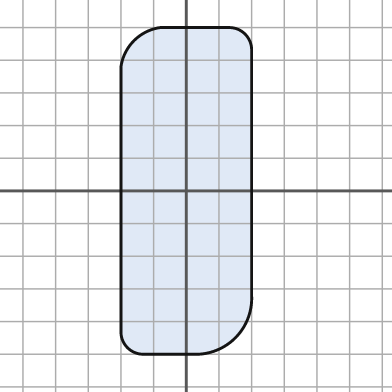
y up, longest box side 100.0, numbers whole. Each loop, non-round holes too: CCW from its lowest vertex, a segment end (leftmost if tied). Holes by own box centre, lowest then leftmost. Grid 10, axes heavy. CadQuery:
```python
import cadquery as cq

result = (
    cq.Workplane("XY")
    .moveTo(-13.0, -50.0)
    .lineTo(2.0, -50.0)
    .threePointArc((15.0, -45.0), (20.0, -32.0))
    .lineTo(20.0, 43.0)
    .threePointArc((18.0, 48.0), (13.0, 50.0))
    .lineTo(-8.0, 50.0)
    .threePointArc((-16.0, 46.0), (-20.0, 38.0))
    .lineTo(-20.0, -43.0)
    .threePointArc((-18.0, -48.0), (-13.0, -50.0))
    .close()
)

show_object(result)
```